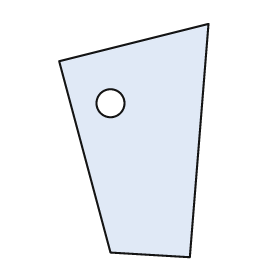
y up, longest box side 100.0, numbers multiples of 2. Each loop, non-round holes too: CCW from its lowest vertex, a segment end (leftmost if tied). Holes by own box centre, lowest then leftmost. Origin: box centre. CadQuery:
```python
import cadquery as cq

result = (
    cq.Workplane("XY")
    .moveTo(24.0, -50.0)
    .lineTo(32.0, 50.0)
    .lineTo(-32.0, 34.0)
    .lineTo(-10.0, -48.0)
    .close()
    .moveTo(-10.0, 16.0)
    .circle(6.0)
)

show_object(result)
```